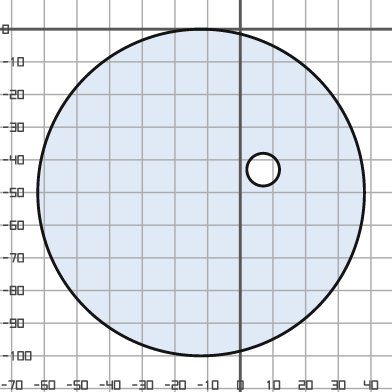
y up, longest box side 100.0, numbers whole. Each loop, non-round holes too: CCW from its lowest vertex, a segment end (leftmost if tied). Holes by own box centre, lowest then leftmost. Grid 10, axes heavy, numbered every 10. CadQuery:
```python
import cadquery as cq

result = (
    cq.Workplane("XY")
    .moveTo(-12.0, -50.0)
    .circle(50.0)
    .moveTo(7.0, -43.0)
    .circle(5.0)
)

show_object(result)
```